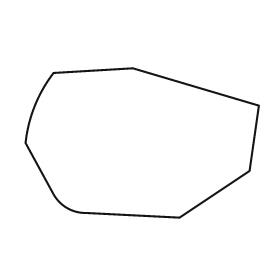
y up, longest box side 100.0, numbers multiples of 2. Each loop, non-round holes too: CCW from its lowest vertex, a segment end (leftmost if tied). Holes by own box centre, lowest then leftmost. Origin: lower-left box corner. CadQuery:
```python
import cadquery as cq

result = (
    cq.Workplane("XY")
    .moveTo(66.0, 0.0)
    .lineTo(96.0, 20.0)
    .lineTo(100.0, 48.0)
    .lineTo(46.0, 64.0)
    .lineTo(12.0, 62.0)
    .threePointArc((4.0, 48.0), (0.0, 32.0))
    .lineTo(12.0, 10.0)
    .threePointArc((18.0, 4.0), (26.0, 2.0))
    .close()
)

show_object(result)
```